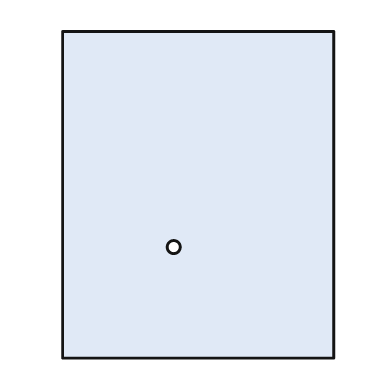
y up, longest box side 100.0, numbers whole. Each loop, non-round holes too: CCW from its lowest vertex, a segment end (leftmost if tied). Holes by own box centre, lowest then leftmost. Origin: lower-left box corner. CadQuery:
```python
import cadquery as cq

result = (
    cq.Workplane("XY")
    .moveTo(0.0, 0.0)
    .lineTo(83.0, 0.0)
    .lineTo(83.0, 100.0)
    .lineTo(0.0, 100.0)
    .close()
    .moveTo(34.0, 34.0)
    .circle(2.0)
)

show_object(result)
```